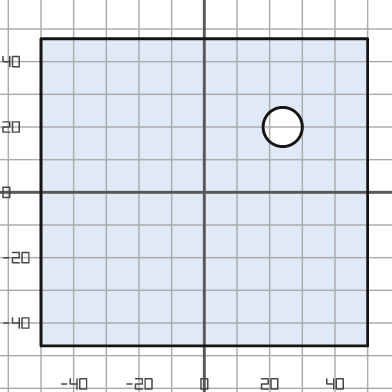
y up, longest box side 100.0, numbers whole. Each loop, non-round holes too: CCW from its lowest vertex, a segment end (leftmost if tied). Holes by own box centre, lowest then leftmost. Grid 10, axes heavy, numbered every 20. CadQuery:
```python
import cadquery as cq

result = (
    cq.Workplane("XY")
    .moveTo(-50.0, -47.0)
    .lineTo(50.0, -47.0)
    .lineTo(50.0, 47.0)
    .lineTo(-50.0, 47.0)
    .close()
    .moveTo(24.0, 20.0)
    .circle(6.0)
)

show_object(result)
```